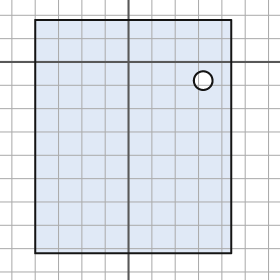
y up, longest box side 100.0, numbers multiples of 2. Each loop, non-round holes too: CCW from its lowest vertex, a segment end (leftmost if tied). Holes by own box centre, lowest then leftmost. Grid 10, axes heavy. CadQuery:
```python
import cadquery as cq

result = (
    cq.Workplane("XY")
    .moveTo(-40.0, -82.0)
    .lineTo(44.0, -82.0)
    .lineTo(44.0, 18.0)
    .lineTo(-40.0, 18.0)
    .close()
    .moveTo(32.0, -8.0)
    .circle(4.0)
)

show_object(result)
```